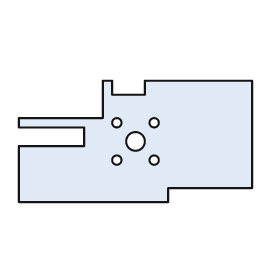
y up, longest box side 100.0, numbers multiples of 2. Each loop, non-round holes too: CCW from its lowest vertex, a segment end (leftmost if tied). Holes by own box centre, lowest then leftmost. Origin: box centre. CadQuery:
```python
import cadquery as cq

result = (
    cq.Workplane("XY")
    .moveTo(-50.0, -26.0)
    .lineTo(14.0, -26.0)
    .lineTo(14.0, -20.0)
    .lineTo(50.0, -20.0)
    .lineTo(50.0, 26.0)
    .lineTo(4.0, 26.0)
    .lineTo(4.0, 20.0)
    .lineTo(-10.0, 20.0)
    .lineTo(-10.0, 26.0)
    .lineTo(-14.0, 26.0)
    .lineTo(-14.0, 10.0)
    .lineTo(-50.0, 10.0)
    .lineTo(-50.0, 6.0)
    .lineTo(-22.0, 6.0)
    .lineTo(-22.0, -2.0)
    .lineTo(-50.0, -2.0)
    .close()
    .moveTo(-8.0, -8.0)
    .circle(2.0)
    .moveTo(8.0, -8.0)
    .circle(2.0)
    .moveTo(0.0, 0.0)
    .circle(4.0)
    .moveTo(-8.0, 8.0)
    .circle(2.0)
    .moveTo(8.0, 8.0)
    .circle(2.0)
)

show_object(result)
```